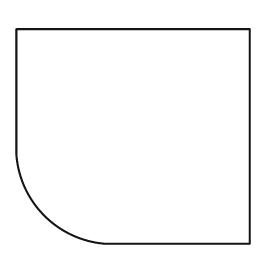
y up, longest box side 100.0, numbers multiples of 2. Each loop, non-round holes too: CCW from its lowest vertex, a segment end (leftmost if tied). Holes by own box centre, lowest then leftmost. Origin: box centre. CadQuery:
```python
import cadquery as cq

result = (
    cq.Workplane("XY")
    .moveTo(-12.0, -46.0)
    .lineTo(50.0, -46.0)
    .lineTo(50.0, 46.0)
    .lineTo(-50.0, 46.0)
    .lineTo(-50.0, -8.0)
    .threePointArc((-38.0, -34.0), (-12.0, -46.0))
    .close()
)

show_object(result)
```